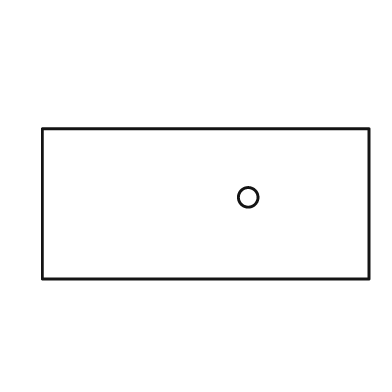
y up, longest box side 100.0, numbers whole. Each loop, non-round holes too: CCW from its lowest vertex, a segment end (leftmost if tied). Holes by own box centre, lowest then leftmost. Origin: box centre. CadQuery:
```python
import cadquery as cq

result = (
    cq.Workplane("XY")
    .moveTo(-50.0, -23.0)
    .lineTo(50.0, -23.0)
    .lineTo(50.0, 23.0)
    .lineTo(-50.0, 23.0)
    .close()
    .moveTo(13.0, 2.0)
    .circle(3.0)
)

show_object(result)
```